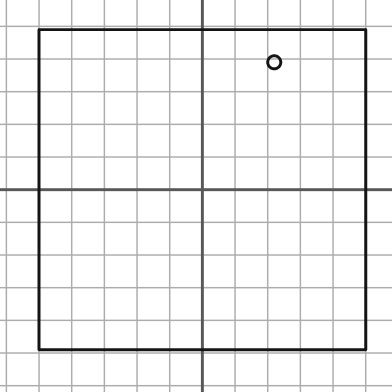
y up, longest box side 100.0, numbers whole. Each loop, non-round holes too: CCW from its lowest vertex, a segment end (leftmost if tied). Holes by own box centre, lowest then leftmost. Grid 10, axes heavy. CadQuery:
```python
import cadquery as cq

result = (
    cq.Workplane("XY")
    .moveTo(-50.0, -49.0)
    .lineTo(50.0, -49.0)
    .lineTo(50.0, 49.0)
    .lineTo(-50.0, 49.0)
    .close()
    .moveTo(22.0, 39.0)
    .circle(2.0)
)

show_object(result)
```